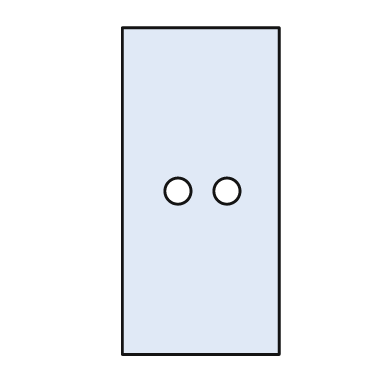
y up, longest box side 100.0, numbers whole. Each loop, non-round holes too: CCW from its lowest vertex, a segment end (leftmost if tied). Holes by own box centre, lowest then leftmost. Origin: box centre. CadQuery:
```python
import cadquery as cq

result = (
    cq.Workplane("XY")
    .moveTo(-24.0, -50.0)
    .lineTo(24.0, -50.0)
    .lineTo(24.0, 50.0)
    .lineTo(-24.0, 50.0)
    .close()
    .moveTo(-7.0, 0.0)
    .circle(4.0)
    .moveTo(8.0, 0.0)
    .circle(4.0)
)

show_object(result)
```